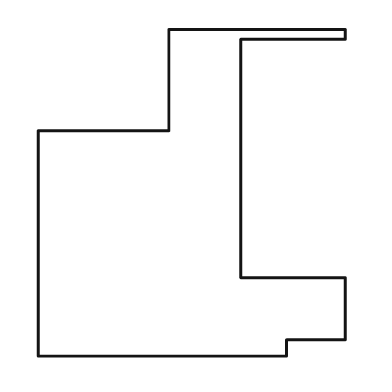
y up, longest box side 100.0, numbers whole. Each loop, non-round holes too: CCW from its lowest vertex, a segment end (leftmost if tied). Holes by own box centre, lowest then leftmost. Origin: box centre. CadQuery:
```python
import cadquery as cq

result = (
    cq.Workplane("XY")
    .moveTo(-47.0, -50.0)
    .lineTo(29.0, -50.0)
    .lineTo(29.0, -45.0)
    .lineTo(47.0, -45.0)
    .lineTo(47.0, -26.0)
    .lineTo(15.0, -26.0)
    .lineTo(15.0, 47.0)
    .lineTo(47.0, 47.0)
    .lineTo(47.0, 50.0)
    .lineTo(-7.0, 50.0)
    .lineTo(-7.0, 19.0)
    .lineTo(-47.0, 19.0)
    .close()
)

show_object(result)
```